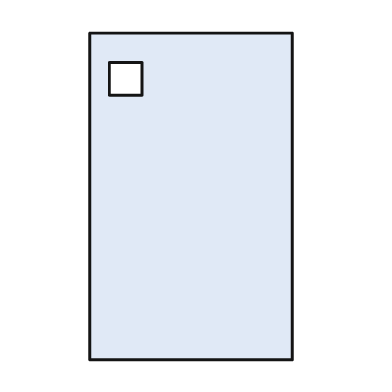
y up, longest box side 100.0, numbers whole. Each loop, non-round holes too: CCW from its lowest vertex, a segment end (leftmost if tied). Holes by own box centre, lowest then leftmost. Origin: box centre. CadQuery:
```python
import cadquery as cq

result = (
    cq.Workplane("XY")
    .moveTo(-31.0, -50.0)
    .lineTo(31.0, -50.0)
    .lineTo(31.0, 50.0)
    .lineTo(-31.0, 50.0)
    .close()
    .moveTo(-25.0, 31.0)
    .lineTo(-15.0, 31.0)
    .lineTo(-15.0, 41.0)
    .lineTo(-25.0, 41.0)
    .close()
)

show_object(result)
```